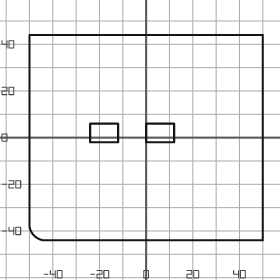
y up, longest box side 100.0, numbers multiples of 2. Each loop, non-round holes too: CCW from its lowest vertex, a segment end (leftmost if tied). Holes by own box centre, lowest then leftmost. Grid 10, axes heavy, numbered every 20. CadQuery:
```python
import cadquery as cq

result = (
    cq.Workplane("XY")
    .moveTo(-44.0, -44.0)
    .lineTo(50.0, -44.0)
    .lineTo(50.0, 44.0)
    .lineTo(-50.0, 44.0)
    .lineTo(-50.0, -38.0)
    .threePointArc((-48.0, -42.0), (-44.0, -44.0))
    .close()
    .moveTo(-24.0, -2.0)
    .lineTo(-12.0, -2.0)
    .lineTo(-12.0, 6.0)
    .lineTo(-24.0, 6.0)
    .close()
    .moveTo(0.0, -2.0)
    .lineTo(12.0, -2.0)
    .lineTo(12.0, 6.0)
    .lineTo(0.0, 6.0)
    .close()
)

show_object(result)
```